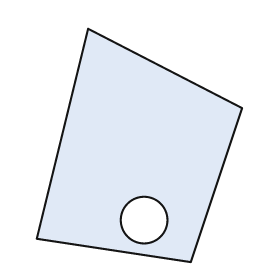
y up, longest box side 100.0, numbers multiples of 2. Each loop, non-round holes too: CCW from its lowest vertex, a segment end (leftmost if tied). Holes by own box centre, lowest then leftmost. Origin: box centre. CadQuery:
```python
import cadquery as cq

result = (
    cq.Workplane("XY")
    .moveTo(22.0, -50.0)
    .lineTo(44.0, 16.0)
    .lineTo(-22.0, 50.0)
    .lineTo(-44.0, -40.0)
    .close()
    .moveTo(2.0, -32.0)
    .circle(10.0)
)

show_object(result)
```